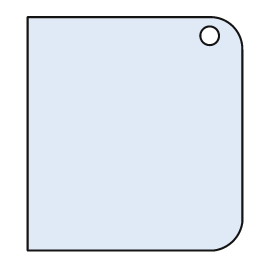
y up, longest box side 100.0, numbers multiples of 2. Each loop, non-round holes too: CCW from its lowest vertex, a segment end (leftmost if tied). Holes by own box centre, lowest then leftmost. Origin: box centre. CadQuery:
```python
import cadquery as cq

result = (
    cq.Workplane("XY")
    .moveTo(-46.0, -50.0)
    .lineTo(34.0, -50.0)
    .threePointArc((42.0, -46.0), (46.0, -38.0))
    .lineTo(46.0, 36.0)
    .threePointArc((42.0, 46.0), (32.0, 50.0))
    .lineTo(-46.0, 50.0)
    .close()
    .moveTo(32.0, 42.0)
    .circle(4.0)
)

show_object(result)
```